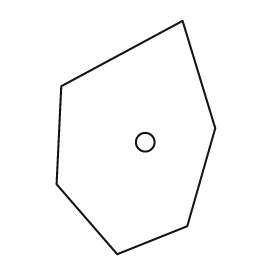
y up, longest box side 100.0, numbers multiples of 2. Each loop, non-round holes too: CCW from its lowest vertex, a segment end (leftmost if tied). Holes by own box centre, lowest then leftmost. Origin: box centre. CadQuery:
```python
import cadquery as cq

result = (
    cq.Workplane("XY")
    .moveTo(-8.0, -50.0)
    .lineTo(22.0, -38.0)
    .lineTo(34.0, 4.0)
    .lineTo(20.0, 50.0)
    .lineTo(-32.0, 22.0)
    .lineTo(-34.0, -20.0)
    .close()
    .moveTo(4.0, -2.0)
    .circle(4.0)
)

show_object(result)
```